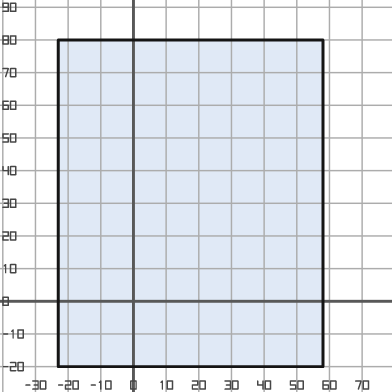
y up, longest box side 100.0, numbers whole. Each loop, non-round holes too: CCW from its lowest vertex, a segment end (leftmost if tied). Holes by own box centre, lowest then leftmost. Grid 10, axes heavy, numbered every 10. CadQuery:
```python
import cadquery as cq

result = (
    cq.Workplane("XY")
    .moveTo(-23.0, -20.0)
    .lineTo(58.0, -20.0)
    .lineTo(58.0, 80.0)
    .lineTo(-23.0, 80.0)
    .close()
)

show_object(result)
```